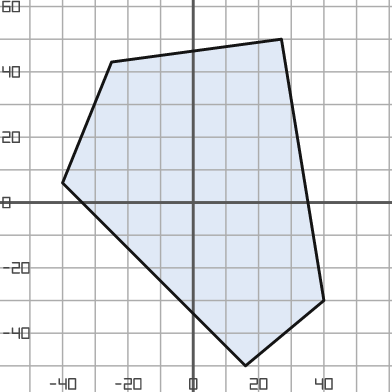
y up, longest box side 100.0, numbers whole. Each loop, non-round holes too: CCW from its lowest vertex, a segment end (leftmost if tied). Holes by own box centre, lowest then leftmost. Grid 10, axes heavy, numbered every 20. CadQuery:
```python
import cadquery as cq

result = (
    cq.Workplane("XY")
    .moveTo(16.0, -50.0)
    .lineTo(40.0, -30.0)
    .lineTo(27.0, 50.0)
    .lineTo(-25.0, 43.0)
    .lineTo(-40.0, 6.0)
    .close()
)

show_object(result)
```